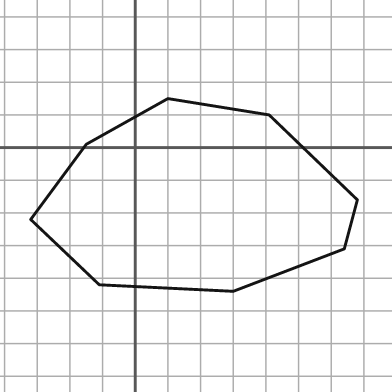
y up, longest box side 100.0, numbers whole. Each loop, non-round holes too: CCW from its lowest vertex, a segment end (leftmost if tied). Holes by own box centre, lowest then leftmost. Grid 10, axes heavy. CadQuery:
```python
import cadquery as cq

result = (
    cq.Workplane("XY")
    .moveTo(30.0, -44.0)
    .lineTo(64.0, -31.0)
    .lineTo(68.0, -16.0)
    .lineTo(41.0, 10.0)
    .lineTo(10.0, 15.0)
    .lineTo(-15.0, 1.0)
    .lineTo(-32.0, -22.0)
    .lineTo(-11.0, -42.0)
    .close()
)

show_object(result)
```